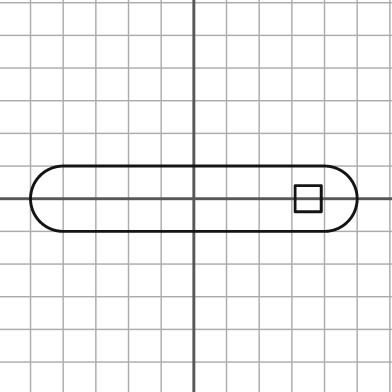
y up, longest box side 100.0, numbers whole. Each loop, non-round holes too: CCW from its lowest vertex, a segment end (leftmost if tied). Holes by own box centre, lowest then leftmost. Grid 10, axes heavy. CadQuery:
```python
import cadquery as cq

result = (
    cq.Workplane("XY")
    .moveTo(-40.0, -10.0)
    .lineTo(40.0, -10.0)
    .threePointArc((50.0, 0.0), (40.0, 10.0))
    .lineTo(-40.0, 10.0)
    .threePointArc((-50.0, 0.0), (-40.0, -10.0))
    .close()
    .moveTo(31.0, -4.0)
    .lineTo(39.0, -4.0)
    .lineTo(39.0, 4.0)
    .lineTo(31.0, 4.0)
    .close()
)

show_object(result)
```